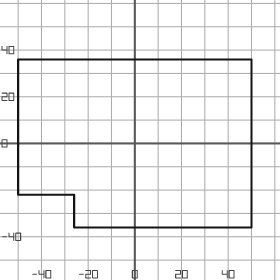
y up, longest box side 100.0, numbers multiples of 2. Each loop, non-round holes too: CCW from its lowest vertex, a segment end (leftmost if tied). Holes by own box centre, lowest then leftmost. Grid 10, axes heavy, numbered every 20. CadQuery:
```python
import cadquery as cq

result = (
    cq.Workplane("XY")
    .moveTo(-26.0, -36.0)
    .lineTo(50.0, -36.0)
    .lineTo(50.0, 36.0)
    .lineTo(-50.0, 36.0)
    .lineTo(-50.0, -22.0)
    .lineTo(-26.0, -22.0)
    .close()
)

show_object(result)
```